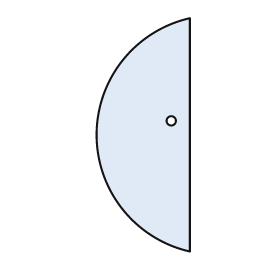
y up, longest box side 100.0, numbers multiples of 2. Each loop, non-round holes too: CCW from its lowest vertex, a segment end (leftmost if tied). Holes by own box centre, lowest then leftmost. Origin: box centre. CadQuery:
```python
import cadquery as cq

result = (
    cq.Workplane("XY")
    .moveTo(20.0, -50.0)
    .lineTo(20.0, 50.0)
    .threePointArc((-20.0, 0.0), (20.0, -50.0))
    .close()
    .moveTo(12.0, 6.0)
    .circle(2.0)
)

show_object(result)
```